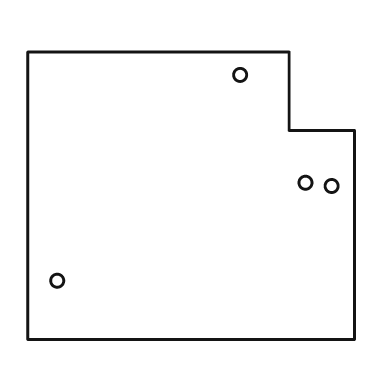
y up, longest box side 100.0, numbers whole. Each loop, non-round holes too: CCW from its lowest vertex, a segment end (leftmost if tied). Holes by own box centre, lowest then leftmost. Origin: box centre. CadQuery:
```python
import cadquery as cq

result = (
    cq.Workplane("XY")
    .moveTo(-50.0, -44.0)
    .lineTo(50.0, -44.0)
    .lineTo(50.0, 20.0)
    .lineTo(30.0, 20.0)
    .lineTo(30.0, 44.0)
    .lineTo(-50.0, 44.0)
    .close()
    .moveTo(-41.0, -26.0)
    .circle(2.0)
    .moveTo(43.0, 3.0)
    .circle(2.0)
    .moveTo(35.0, 4.0)
    .circle(2.0)
    .moveTo(15.0, 37.0)
    .circle(2.0)
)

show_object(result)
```